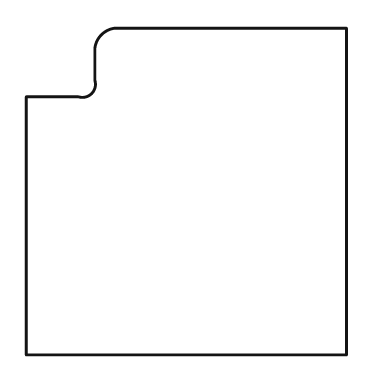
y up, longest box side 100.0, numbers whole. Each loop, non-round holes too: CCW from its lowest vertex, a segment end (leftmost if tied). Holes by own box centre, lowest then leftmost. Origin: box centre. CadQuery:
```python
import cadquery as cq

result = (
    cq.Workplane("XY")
    .moveTo(-49.0, -50.0)
    .lineTo(49.0, -50.0)
    .lineTo(49.0, 50.0)
    .lineTo(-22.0, 50.0)
    .threePointArc((-26.0, 48.0), (-28.0, 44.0))
    .lineTo(-28.0, 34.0)
    .threePointArc((-29.0, 30.0), (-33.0, 29.0))
    .lineTo(-49.0, 29.0)
    .close()
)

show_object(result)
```